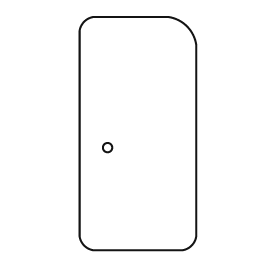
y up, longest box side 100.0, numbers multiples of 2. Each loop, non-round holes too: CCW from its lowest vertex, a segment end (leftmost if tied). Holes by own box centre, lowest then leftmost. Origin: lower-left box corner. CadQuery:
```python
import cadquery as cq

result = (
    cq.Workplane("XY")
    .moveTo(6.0, 0.0)
    .lineTo(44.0, 0.0)
    .threePointArc((48.0, 2.0), (50.0, 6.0))
    .lineTo(50.0, 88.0)
    .threePointArc((46.0, 96.0), (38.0, 100.0))
    .lineTo(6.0, 100.0)
    .threePointArc((2.0, 98.0), (0.0, 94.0))
    .lineTo(0.0, 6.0)
    .threePointArc((2.0, 2.0), (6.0, 0.0))
    .close()
    .moveTo(12.0, 44.0)
    .circle(2.0)
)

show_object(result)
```